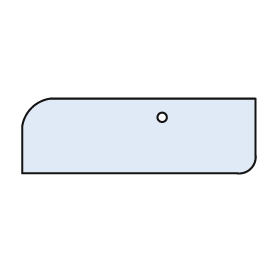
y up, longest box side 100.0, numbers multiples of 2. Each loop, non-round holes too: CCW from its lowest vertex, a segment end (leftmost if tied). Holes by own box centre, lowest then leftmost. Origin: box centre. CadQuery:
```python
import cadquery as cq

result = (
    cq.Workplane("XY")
    .moveTo(-50.0, -16.0)
    .lineTo(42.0, -16.0)
    .threePointArc((48.0, -14.0), (50.0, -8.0))
    .lineTo(50.0, 16.0)
    .lineTo(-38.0, 16.0)
    .threePointArc((-46.0, 12.0), (-50.0, 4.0))
    .close()
    .moveTo(10.0, 8.0)
    .circle(2.0)
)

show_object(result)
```